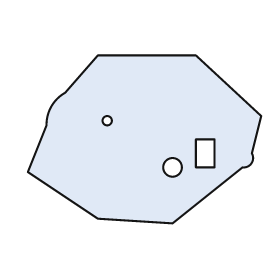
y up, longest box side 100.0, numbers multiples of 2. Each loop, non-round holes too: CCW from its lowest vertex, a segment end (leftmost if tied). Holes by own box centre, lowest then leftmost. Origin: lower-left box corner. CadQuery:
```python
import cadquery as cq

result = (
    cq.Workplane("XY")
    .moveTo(62.0, 0.0)
    .lineTo(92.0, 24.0)
    .threePointArc((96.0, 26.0), (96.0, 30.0))
    .lineTo(100.0, 46.0)
    .lineTo(72.0, 72.0)
    .lineTo(30.0, 72.0)
    .lineTo(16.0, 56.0)
    .threePointArc((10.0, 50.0), (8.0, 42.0))
    .lineTo(0.0, 22.0)
    .lineTo(30.0, 2.0)
    .close()
    .moveTo(62.0, 24.0)
    .circle(4.0)
    .moveTo(72.0, 24.0)
    .lineTo(80.0, 24.0)
    .lineTo(80.0, 36.0)
    .lineTo(72.0, 36.0)
    .close()
    .moveTo(34.0, 44.0)
    .circle(2.0)
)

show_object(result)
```